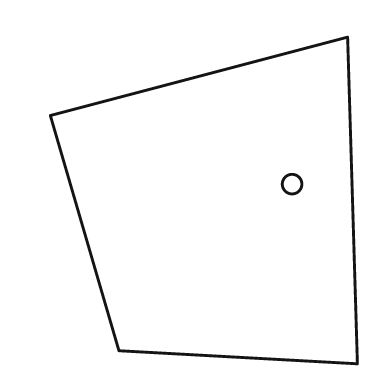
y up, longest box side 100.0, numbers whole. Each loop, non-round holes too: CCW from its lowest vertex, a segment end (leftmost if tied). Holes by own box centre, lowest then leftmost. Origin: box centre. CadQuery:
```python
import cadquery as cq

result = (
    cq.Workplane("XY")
    .moveTo(47.0, -50.0)
    .lineTo(44.0, 50.0)
    .lineTo(-47.0, 26.0)
    .lineTo(-26.0, -46.0)
    .close()
    .moveTo(27.0, 5.0)
    .circle(3.0)
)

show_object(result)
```